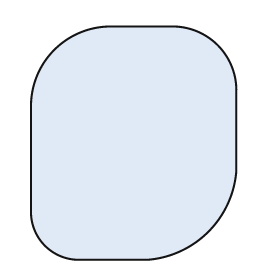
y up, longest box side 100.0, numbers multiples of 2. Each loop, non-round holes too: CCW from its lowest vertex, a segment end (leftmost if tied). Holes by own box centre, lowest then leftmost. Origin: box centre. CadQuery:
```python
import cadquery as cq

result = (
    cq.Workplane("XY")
    .moveTo(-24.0, -50.0)
    .lineTo(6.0, -50.0)
    .threePointArc((32.0, -38.0), (44.0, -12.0))
    .lineTo(44.0, 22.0)
    .threePointArc((36.0, 42.0), (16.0, 50.0))
    .lineTo(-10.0, 50.0)
    .threePointArc((-34.0, 40.0), (-44.0, 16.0))
    .lineTo(-44.0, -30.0)
    .threePointArc((-38.0, -44.0), (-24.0, -50.0))
    .close()
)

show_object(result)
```